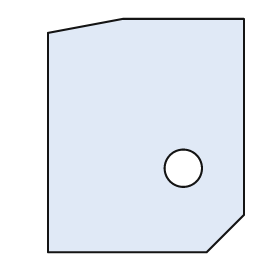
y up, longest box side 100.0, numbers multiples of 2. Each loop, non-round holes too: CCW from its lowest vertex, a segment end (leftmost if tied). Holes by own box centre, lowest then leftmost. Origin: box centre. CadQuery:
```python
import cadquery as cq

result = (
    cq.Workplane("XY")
    .moveTo(-42.0, -50.0)
    .lineTo(26.0, -50.0)
    .lineTo(42.0, -34.0)
    .lineTo(42.0, 50.0)
    .lineTo(-10.0, 50.0)
    .lineTo(-42.0, 44.0)
    .close()
    .moveTo(16.0, -14.0)
    .circle(8.0)
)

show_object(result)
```